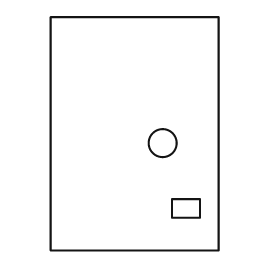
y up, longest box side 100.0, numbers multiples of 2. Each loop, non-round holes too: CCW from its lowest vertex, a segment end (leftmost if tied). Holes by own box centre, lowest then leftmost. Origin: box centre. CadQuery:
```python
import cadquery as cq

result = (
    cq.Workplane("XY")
    .moveTo(-36.0, -50.0)
    .lineTo(36.0, -50.0)
    .lineTo(36.0, 50.0)
    .lineTo(-36.0, 50.0)
    .close()
    .moveTo(16.0, -36.0)
    .lineTo(28.0, -36.0)
    .lineTo(28.0, -28.0)
    .lineTo(16.0, -28.0)
    .close()
    .moveTo(12.0, -4.0)
    .circle(6.0)
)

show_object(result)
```